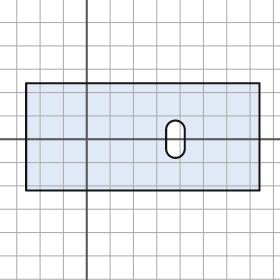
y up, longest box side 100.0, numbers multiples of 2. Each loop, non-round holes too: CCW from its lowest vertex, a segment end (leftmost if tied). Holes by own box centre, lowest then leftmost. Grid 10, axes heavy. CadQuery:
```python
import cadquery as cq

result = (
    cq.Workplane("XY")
    .moveTo(-26.0, -22.0)
    .lineTo(74.0, -22.0)
    .lineTo(74.0, 24.0)
    .lineTo(-26.0, 24.0)
    .close()
    .moveTo(34.0, -4.0)
    .threePointArc((38.0, -8.0), (42.0, -4.0))
    .lineTo(42.0, 4.0)
    .threePointArc((38.0, 8.0), (34.0, 4.0))
    .close()
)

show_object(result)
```